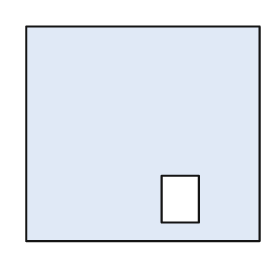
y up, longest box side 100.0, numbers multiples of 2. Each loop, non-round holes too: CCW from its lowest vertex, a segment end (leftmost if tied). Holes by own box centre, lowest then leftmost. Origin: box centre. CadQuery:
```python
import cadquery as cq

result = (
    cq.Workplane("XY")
    .moveTo(-50.0, -46.0)
    .lineTo(50.0, -46.0)
    .lineTo(50.0, 46.0)
    .lineTo(-50.0, 46.0)
    .close()
    .moveTo(8.0, -38.0)
    .lineTo(24.0, -38.0)
    .lineTo(24.0, -18.0)
    .lineTo(8.0, -18.0)
    .close()
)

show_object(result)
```